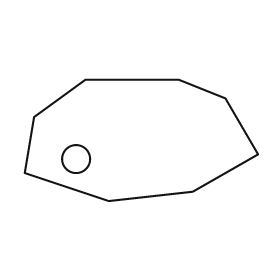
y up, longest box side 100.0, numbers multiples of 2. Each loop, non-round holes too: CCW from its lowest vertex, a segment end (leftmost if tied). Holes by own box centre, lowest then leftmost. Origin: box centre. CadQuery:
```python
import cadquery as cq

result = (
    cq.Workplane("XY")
    .moveTo(-14.0, -26.0)
    .lineTo(22.0, -22.0)
    .lineTo(50.0, -6.0)
    .lineTo(36.0, 18.0)
    .lineTo(16.0, 26.0)
    .lineTo(-24.0, 26.0)
    .lineTo(-46.0, 10.0)
    .lineTo(-50.0, -14.0)
    .close()
    .moveTo(-28.0, -8.0)
    .circle(6.0)
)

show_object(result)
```